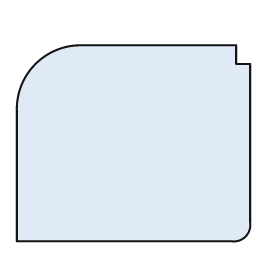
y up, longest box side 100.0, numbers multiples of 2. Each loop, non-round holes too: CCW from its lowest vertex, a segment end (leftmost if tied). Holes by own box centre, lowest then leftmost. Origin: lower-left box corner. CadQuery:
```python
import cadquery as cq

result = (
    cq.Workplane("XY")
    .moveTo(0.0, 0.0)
    .lineTo(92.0, 0.0)
    .threePointArc((98.0, 2.0), (100.0, 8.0))
    .lineTo(100.0, 76.0)
    .lineTo(94.0, 76.0)
    .lineTo(94.0, 84.0)
    .lineTo(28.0, 84.0)
    .threePointArc((8.0, 76.0), (0.0, 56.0))
    .close()
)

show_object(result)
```